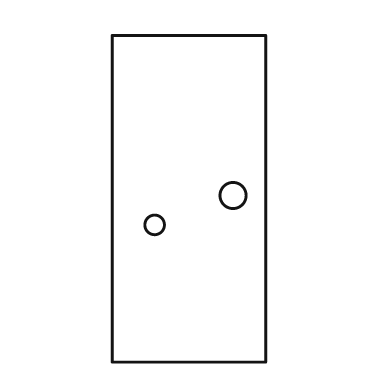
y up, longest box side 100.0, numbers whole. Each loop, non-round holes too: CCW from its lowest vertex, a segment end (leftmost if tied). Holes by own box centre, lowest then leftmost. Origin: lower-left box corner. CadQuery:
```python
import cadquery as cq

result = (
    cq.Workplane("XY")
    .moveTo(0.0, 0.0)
    .lineTo(47.0, 0.0)
    .lineTo(47.0, 100.0)
    .lineTo(0.0, 100.0)
    .close()
    .moveTo(13.0, 42.0)
    .circle(3.0)
    .moveTo(37.0, 51.0)
    .circle(4.0)
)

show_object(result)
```